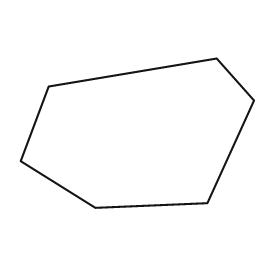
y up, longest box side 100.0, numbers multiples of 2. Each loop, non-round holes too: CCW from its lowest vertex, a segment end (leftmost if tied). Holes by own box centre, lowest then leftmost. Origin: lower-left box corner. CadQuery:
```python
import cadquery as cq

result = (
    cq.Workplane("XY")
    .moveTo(32.0, 0.0)
    .lineTo(80.0, 2.0)
    .lineTo(100.0, 46.0)
    .lineTo(84.0, 64.0)
    .lineTo(12.0, 52.0)
    .lineTo(0.0, 20.0)
    .close()
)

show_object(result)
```